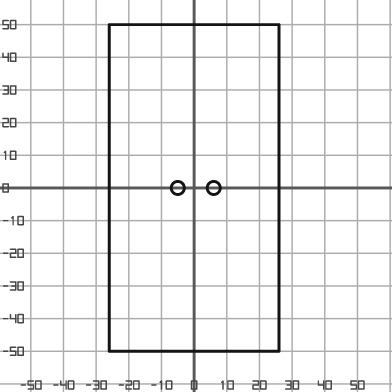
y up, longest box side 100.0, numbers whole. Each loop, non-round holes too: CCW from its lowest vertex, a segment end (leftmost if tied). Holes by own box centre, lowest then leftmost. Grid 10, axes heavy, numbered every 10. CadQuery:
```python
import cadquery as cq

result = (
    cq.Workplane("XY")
    .moveTo(-26.0, -50.0)
    .lineTo(26.0, -50.0)
    .lineTo(26.0, 50.0)
    .lineTo(-26.0, 50.0)
    .close()
    .moveTo(-5.0, 0.0)
    .circle(2.0)
    .moveTo(6.0, 0.0)
    .circle(2.0)
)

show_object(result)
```